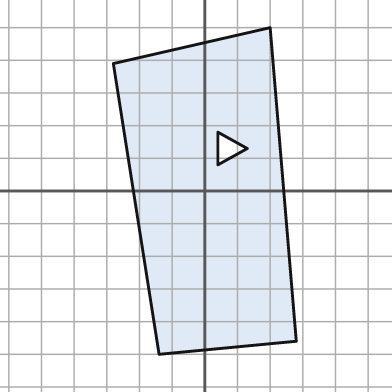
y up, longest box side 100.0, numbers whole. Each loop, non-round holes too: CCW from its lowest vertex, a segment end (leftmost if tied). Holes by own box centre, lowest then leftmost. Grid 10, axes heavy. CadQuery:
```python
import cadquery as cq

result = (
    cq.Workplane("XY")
    .moveTo(-14.0, -50.0)
    .lineTo(28.0, -46.0)
    .lineTo(20.0, 50.0)
    .lineTo(-28.0, 39.0)
    .close()
    .moveTo(4.0, 8.0)
    .lineTo(13.0, 13.0)
    .lineTo(4.0, 18.0)
    .close()
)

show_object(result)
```